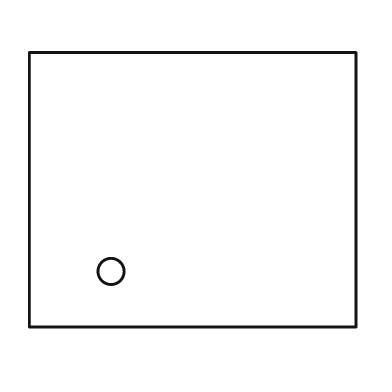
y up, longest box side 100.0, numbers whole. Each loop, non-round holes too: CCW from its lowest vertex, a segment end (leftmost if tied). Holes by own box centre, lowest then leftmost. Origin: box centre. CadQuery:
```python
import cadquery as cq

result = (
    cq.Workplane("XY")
    .moveTo(-50.0, -42.0)
    .lineTo(50.0, -42.0)
    .lineTo(50.0, 42.0)
    .lineTo(-50.0, 42.0)
    .close()
    .moveTo(-25.0, -25.0)
    .circle(4.0)
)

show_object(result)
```